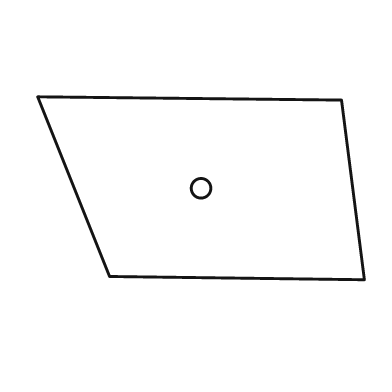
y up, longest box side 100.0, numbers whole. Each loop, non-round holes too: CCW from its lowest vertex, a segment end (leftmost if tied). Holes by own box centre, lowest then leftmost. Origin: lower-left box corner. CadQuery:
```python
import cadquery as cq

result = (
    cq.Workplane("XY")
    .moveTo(100.0, 0.0)
    .lineTo(93.0, 55.0)
    .lineTo(0.0, 56.0)
    .lineTo(22.0, 1.0)
    .close()
    .moveTo(50.0, 28.0)
    .circle(3.0)
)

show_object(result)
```